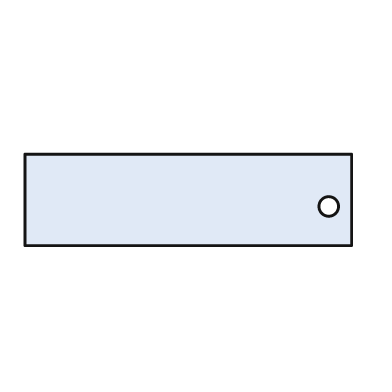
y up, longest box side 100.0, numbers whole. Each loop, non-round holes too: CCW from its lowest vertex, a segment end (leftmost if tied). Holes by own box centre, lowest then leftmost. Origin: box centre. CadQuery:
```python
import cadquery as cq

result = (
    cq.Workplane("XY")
    .moveTo(-50.0, -14.0)
    .lineTo(50.0, -14.0)
    .lineTo(50.0, 14.0)
    .lineTo(-50.0, 14.0)
    .close()
    .moveTo(43.0, -2.0)
    .circle(3.0)
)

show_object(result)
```